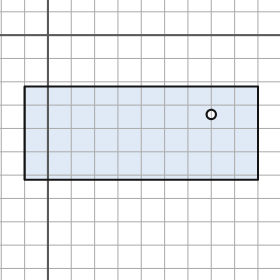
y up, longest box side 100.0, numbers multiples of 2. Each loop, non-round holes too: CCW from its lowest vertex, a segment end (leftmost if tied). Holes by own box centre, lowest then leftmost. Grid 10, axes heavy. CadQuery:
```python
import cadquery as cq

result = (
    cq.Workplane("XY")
    .moveTo(-10.0, -62.0)
    .lineTo(90.0, -62.0)
    .lineTo(90.0, -22.0)
    .lineTo(-10.0, -22.0)
    .close()
    .moveTo(70.0, -34.0)
    .circle(2.0)
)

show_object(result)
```